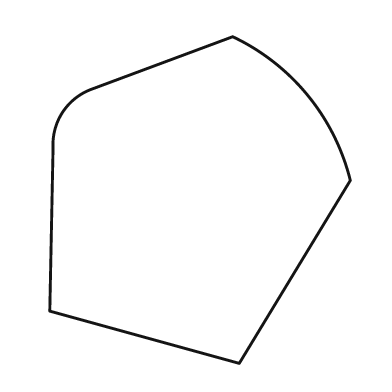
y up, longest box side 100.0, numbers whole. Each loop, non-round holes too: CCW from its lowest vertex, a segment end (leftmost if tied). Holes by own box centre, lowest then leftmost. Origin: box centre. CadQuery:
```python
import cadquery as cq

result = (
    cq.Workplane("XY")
    .moveTo(12.0, -50.0)
    .lineTo(46.0, 6.0)
    .threePointArc((33.0, 32.0), (10.0, 50.0))
    .lineTo(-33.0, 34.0)
    .threePointArc((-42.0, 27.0), (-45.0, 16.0))
    .lineTo(-46.0, -34.0)
    .close()
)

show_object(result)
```